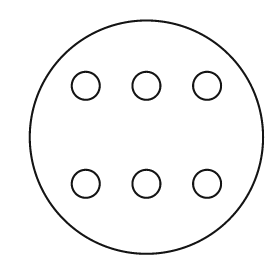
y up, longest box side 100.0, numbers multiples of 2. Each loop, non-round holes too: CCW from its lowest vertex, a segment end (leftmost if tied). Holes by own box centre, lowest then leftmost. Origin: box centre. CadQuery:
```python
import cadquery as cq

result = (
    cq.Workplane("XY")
    .moveTo(0.0, 0.0)
    .circle(50.0)
    .moveTo(-26.0, -20.0)
    .circle(6.0)
    .moveTo(0.0, -20.0)
    .circle(6.0)
    .moveTo(26.0, -20.0)
    .circle(6.0)
    .moveTo(-26.0, 22.0)
    .circle(6.0)
    .moveTo(0.0, 22.0)
    .circle(6.0)
    .moveTo(26.0, 22.0)
    .circle(6.0)
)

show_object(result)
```